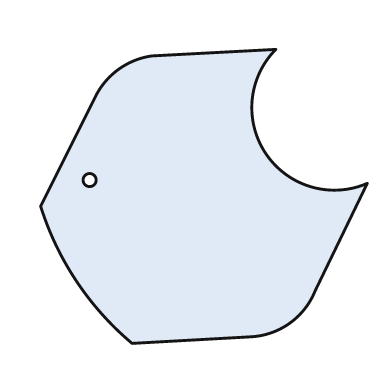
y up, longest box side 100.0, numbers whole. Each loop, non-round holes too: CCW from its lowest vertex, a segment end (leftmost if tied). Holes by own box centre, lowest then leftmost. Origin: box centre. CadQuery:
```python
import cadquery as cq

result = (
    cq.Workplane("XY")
    .moveTo(-22.0, -45.0)
    .lineTo(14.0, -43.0)
    .threePointArc((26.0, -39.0), (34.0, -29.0))
    .lineTo(50.0, 4.0)
    .threePointArc((19.0, 13.0), (22.0, 45.0))
    .lineTo(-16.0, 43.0)
    .threePointArc((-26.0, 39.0), (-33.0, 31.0))
    .lineTo(-50.0, -3.0)
    .threePointArc((-39.0, -26.0), (-22.0, -45.0))
    .close()
    .moveTo(-35.0, 5.0)
    .circle(2.0)
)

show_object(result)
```